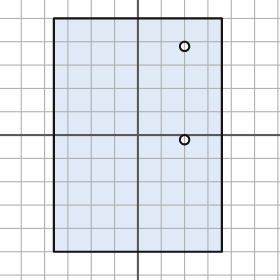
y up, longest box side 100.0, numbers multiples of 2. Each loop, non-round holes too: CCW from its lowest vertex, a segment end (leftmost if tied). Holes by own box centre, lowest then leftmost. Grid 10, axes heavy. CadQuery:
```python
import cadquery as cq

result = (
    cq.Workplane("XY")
    .moveTo(-36.0, -50.0)
    .lineTo(36.0, -50.0)
    .lineTo(36.0, 50.0)
    .lineTo(-36.0, 50.0)
    .close()
    .moveTo(20.0, -2.0)
    .circle(2.0)
    .moveTo(20.0, 38.0)
    .circle(2.0)
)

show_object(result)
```